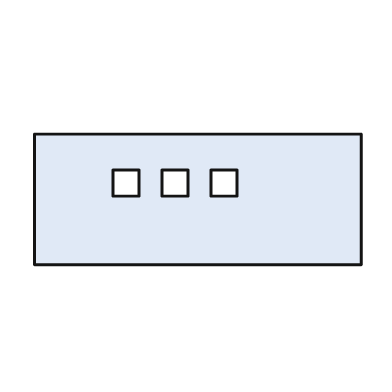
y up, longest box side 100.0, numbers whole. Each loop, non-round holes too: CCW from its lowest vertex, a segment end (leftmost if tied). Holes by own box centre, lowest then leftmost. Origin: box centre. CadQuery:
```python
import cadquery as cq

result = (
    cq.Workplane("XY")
    .moveTo(-50.0, -20.0)
    .lineTo(50.0, -20.0)
    .lineTo(50.0, 20.0)
    .lineTo(-50.0, 20.0)
    .close()
    .moveTo(-26.0, 1.0)
    .lineTo(-18.0, 1.0)
    .lineTo(-18.0, 9.0)
    .lineTo(-26.0, 9.0)
    .close()
    .moveTo(-11.0, 1.0)
    .lineTo(-3.0, 1.0)
    .lineTo(-3.0, 9.0)
    .lineTo(-11.0, 9.0)
    .close()
    .moveTo(4.0, 1.0)
    .lineTo(12.0, 1.0)
    .lineTo(12.0, 9.0)
    .lineTo(4.0, 9.0)
    .close()
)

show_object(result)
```